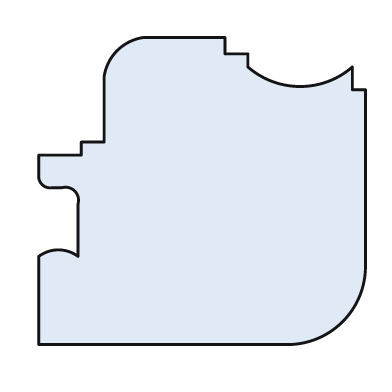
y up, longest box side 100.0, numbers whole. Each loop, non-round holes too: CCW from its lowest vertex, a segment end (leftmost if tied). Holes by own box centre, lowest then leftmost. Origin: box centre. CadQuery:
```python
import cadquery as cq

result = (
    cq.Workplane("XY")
    .moveTo(-50.0, -47.0)
    .lineTo(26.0, -47.0)
    .threePointArc((43.0, -40.0), (50.0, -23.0))
    .lineTo(50.0, 31.0)
    .lineTo(46.0, 31.0)
    .lineTo(46.0, 38.0)
    .threePointArc((30.0, 32.0), (14.0, 38.0))
    .lineTo(14.0, 42.0)
    .lineTo(7.0, 42.0)
    .lineTo(7.0, 47.0)
    .lineTo(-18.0, 47.0)
    .threePointArc((-26.0, 43.0), (-30.0, 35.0))
    .lineTo(-30.0, 15.0)
    .lineTo(-37.0, 15.0)
    .lineTo(-37.0, 11.0)
    .lineTo(-50.0, 11.0)
    .lineTo(-50.0, 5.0)
    .threePointArc((-49.0, 2.0), (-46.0, 1.0))
    .lineTo(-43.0, 1.0)
    .threePointArc((-39.0, 0.0), (-38.0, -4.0))
    .lineTo(-38.0, -20.0)
    .threePointArc((-44.0, -18.0), (-50.0, -20.0))
    .close()
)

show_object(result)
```